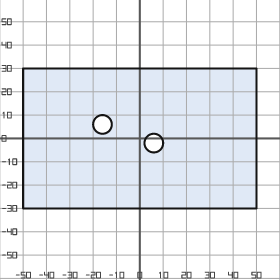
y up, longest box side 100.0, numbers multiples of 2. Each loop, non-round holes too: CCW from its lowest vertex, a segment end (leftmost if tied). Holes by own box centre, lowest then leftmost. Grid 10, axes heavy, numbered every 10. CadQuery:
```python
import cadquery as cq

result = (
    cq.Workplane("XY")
    .moveTo(-50.0, -30.0)
    .lineTo(50.0, -30.0)
    .lineTo(50.0, 30.0)
    .lineTo(-50.0, 30.0)
    .close()
    .moveTo(6.0, -2.0)
    .circle(4.0)
    .moveTo(-16.0, 6.0)
    .circle(4.0)
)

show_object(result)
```